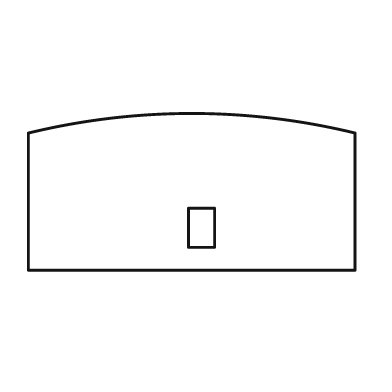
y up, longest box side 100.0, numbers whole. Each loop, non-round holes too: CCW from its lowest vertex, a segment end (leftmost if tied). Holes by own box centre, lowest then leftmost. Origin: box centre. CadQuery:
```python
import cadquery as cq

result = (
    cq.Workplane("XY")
    .moveTo(-50.0, -24.0)
    .lineTo(50.0, -24.0)
    .lineTo(50.0, 18.0)
    .threePointArc((0.0, 24.0), (-50.0, 18.0))
    .close()
    .moveTo(-1.0, -17.0)
    .lineTo(7.0, -17.0)
    .lineTo(7.0, -5.0)
    .lineTo(-1.0, -5.0)
    .close()
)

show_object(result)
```